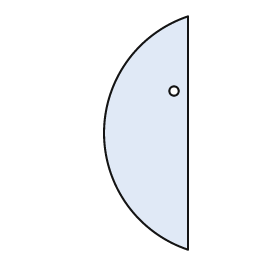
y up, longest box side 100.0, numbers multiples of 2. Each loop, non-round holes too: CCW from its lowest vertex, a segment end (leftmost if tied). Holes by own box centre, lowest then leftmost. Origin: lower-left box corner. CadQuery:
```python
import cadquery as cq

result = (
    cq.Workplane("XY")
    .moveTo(36.0, 0.0)
    .lineTo(36.0, 100.0)
    .threePointArc((0.0, 50.0), (36.0, 0.0))
    .close()
    .moveTo(30.0, 68.0)
    .circle(2.0)
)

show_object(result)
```